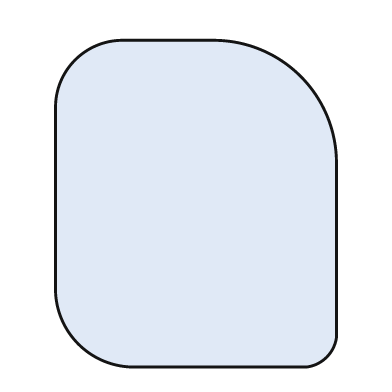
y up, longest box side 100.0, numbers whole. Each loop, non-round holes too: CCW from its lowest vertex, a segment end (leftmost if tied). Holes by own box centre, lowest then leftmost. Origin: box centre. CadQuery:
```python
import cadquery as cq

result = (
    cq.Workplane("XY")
    .moveTo(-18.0, -50.0)
    .lineTo(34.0, -50.0)
    .threePointArc((40.0, -47.0), (43.0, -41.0))
    .lineTo(43.0, 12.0)
    .threePointArc((32.0, 39.0), (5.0, 50.0))
    .lineTo(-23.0, 50.0)
    .threePointArc((-37.0, 44.0), (-43.0, 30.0))
    .lineTo(-43.0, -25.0)
    .threePointArc((-36.0, -43.0), (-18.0, -50.0))
    .close()
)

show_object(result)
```